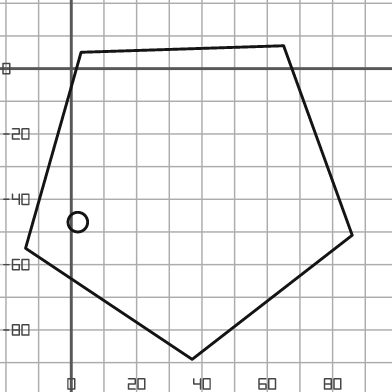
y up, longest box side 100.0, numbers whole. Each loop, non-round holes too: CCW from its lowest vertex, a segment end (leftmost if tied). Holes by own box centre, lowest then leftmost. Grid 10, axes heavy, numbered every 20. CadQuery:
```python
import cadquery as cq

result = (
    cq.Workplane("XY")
    .moveTo(37.0, -89.0)
    .lineTo(86.0, -51.0)
    .lineTo(65.0, 7.0)
    .lineTo(3.0, 5.0)
    .lineTo(-14.0, -55.0)
    .close()
    .moveTo(2.0, -47.0)
    .circle(3.0)
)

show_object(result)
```